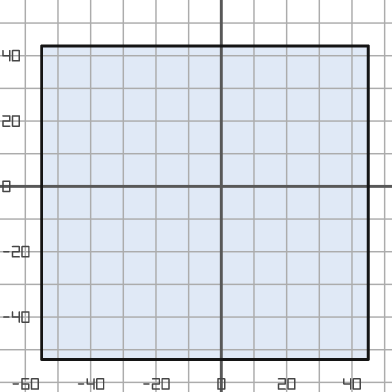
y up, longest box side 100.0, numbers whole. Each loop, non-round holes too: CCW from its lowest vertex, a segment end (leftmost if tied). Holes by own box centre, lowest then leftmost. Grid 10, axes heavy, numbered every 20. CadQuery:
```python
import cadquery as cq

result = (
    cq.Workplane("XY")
    .moveTo(-55.0, -53.0)
    .lineTo(45.0, -53.0)
    .lineTo(45.0, 43.0)
    .lineTo(-55.0, 43.0)
    .close()
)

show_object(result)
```